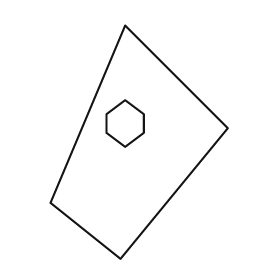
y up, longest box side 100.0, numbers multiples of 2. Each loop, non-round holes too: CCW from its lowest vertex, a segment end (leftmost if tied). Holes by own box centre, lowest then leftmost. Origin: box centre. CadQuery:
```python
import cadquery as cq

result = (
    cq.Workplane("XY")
    .moveTo(-8.0, -50.0)
    .lineTo(38.0, 6.0)
    .lineTo(-6.0, 50.0)
    .lineTo(-38.0, -26.0)
    .close()
    .moveTo(-6.0, -2.0)
    .lineTo(2.0, 4.0)
    .lineTo(2.0, 12.0)
    .lineTo(-6.0, 18.0)
    .lineTo(-14.0, 12.0)
    .lineTo(-14.0, 4.0)
    .close()
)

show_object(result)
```